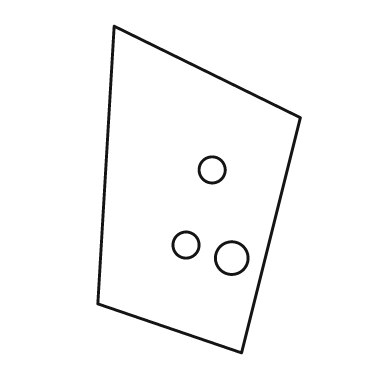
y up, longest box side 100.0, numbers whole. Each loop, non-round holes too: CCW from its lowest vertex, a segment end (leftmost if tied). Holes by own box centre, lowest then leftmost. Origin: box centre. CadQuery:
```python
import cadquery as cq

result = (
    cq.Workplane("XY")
    .moveTo(13.0, -50.0)
    .lineTo(31.0, 22.0)
    .lineTo(-26.0, 50.0)
    .lineTo(-31.0, -35.0)
    .close()
    .moveTo(10.0, -21.0)
    .circle(5.0)
    .moveTo(-4.0, -17.0)
    .circle(4.0)
    .moveTo(4.0, 6.0)
    .circle(4.0)
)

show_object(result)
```